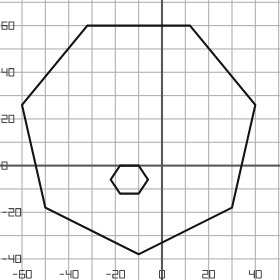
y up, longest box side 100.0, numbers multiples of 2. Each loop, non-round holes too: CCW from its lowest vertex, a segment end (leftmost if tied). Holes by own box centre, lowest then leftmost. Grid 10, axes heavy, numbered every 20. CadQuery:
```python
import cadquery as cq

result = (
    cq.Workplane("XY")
    .moveTo(-10.0, -38.0)
    .lineTo(30.0, -18.0)
    .lineTo(40.0, 26.0)
    .lineTo(12.0, 60.0)
    .lineTo(-32.0, 60.0)
    .lineTo(-60.0, 26.0)
    .lineTo(-50.0, -18.0)
    .close()
    .moveTo(-18.0, -12.0)
    .lineTo(-10.0, -12.0)
    .lineTo(-6.0, -6.0)
    .lineTo(-10.0, 0.0)
    .lineTo(-18.0, 0.0)
    .lineTo(-22.0, -6.0)
    .close()
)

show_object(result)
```